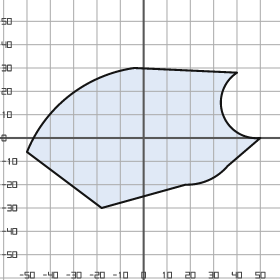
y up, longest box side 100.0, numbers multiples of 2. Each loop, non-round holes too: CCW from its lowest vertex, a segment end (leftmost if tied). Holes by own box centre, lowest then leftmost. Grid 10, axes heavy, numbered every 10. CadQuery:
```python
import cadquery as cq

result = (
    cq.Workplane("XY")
    .moveTo(-18.0, -30.0)
    .lineTo(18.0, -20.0)
    .threePointArc((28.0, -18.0), (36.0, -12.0))
    .lineTo(50.0, 0.0)
    .threePointArc((34.0, 10.0), (40.0, 28.0))
    .lineTo(-4.0, 30.0)
    .threePointArc((-32.0, 18.0), (-50.0, -6.0))
    .close()
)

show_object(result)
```